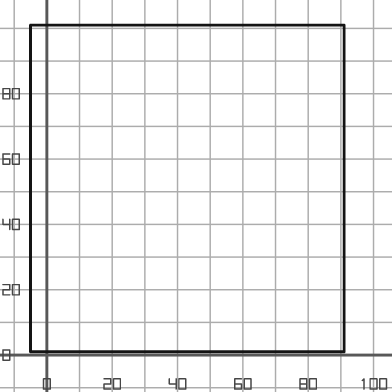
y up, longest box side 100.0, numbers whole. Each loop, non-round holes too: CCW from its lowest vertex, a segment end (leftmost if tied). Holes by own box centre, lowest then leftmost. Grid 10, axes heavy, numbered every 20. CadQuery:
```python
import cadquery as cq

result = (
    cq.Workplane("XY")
    .moveTo(-5.0, 1.0)
    .lineTo(91.0, 1.0)
    .lineTo(91.0, 101.0)
    .lineTo(-5.0, 101.0)
    .close()
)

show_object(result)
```